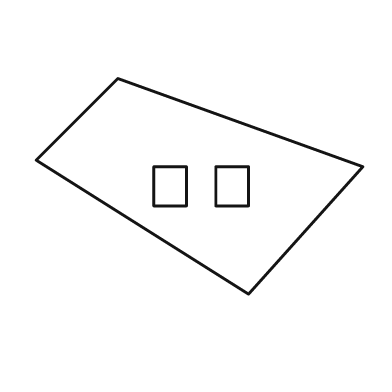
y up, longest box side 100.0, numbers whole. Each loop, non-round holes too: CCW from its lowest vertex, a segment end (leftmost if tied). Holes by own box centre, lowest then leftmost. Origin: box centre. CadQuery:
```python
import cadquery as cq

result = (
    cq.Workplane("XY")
    .moveTo(15.0, -33.0)
    .lineTo(50.0, 6.0)
    .lineTo(-25.0, 33.0)
    .lineTo(-50.0, 8.0)
    .close()
    .moveTo(-14.0, -6.0)
    .lineTo(-4.0, -6.0)
    .lineTo(-4.0, 6.0)
    .lineTo(-14.0, 6.0)
    .close()
    .moveTo(5.0, -6.0)
    .lineTo(15.0, -6.0)
    .lineTo(15.0, 6.0)
    .lineTo(5.0, 6.0)
    .close()
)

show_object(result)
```